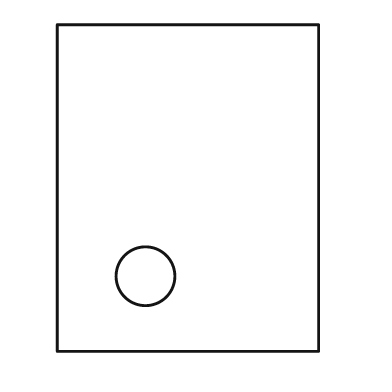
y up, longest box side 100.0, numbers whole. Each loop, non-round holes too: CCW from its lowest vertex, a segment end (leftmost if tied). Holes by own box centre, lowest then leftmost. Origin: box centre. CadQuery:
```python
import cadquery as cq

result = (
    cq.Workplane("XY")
    .moveTo(-40.0, -50.0)
    .lineTo(40.0, -50.0)
    .lineTo(40.0, 50.0)
    .lineTo(-40.0, 50.0)
    .close()
    .moveTo(-13.0, -27.0)
    .circle(9.0)
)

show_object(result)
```